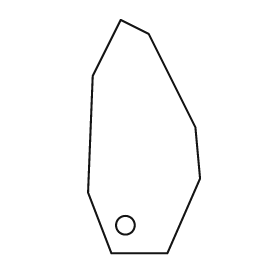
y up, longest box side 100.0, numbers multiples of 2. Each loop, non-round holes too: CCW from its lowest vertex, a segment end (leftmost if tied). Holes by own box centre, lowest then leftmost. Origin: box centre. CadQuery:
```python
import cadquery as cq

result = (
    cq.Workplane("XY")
    .moveTo(-14.0, -50.0)
    .lineTo(10.0, -50.0)
    .lineTo(24.0, -18.0)
    .lineTo(22.0, 4.0)
    .lineTo(2.0, 44.0)
    .lineTo(-10.0, 50.0)
    .lineTo(-22.0, 26.0)
    .lineTo(-24.0, -24.0)
    .close()
    .moveTo(-8.0, -38.0)
    .circle(4.0)
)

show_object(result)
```